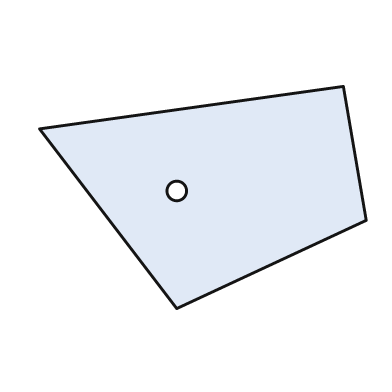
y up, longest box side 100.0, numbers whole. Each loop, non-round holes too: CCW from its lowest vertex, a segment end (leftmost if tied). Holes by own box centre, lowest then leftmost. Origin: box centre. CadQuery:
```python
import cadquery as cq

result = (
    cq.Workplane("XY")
    .moveTo(-8.0, -34.0)
    .lineTo(50.0, -7.0)
    .lineTo(43.0, 34.0)
    .lineTo(-50.0, 21.0)
    .close()
    .moveTo(-8.0, 2.0)
    .circle(3.0)
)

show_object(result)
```